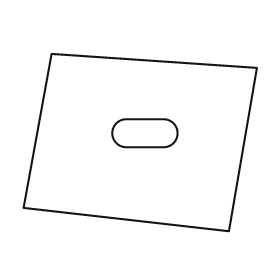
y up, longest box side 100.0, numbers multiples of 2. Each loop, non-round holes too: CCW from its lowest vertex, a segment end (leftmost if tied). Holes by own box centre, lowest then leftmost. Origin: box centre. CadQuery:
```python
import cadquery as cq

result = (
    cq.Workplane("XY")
    .moveTo(38.0, -38.0)
    .lineTo(50.0, 32.0)
    .lineTo(-38.0, 38.0)
    .lineTo(-50.0, -28.0)
    .close()
    .moveTo(-6.0, -2.0)
    .lineTo(10.0, -2.0)
    .threePointArc((16.0, 4.0), (10.0, 10.0))
    .lineTo(-6.0, 10.0)
    .threePointArc((-12.0, 4.0), (-6.0, -2.0))
    .close()
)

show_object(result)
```